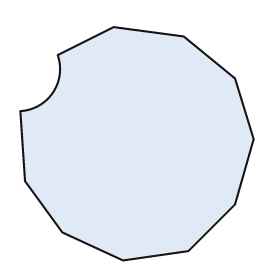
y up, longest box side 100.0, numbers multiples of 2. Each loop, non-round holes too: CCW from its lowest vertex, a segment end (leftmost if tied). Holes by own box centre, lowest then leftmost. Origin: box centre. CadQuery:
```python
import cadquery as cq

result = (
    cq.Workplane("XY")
    .moveTo(-6.0, -50.0)
    .lineTo(22.0, -46.0)
    .lineTo(42.0, -26.0)
    .lineTo(50.0, 2.0)
    .lineTo(42.0, 28.0)
    .lineTo(20.0, 46.0)
    .lineTo(-10.0, 50.0)
    .lineTo(-34.0, 38.0)
    .threePointArc((-36.0, 22.0), (-50.0, 14.0))
    .lineTo(-48.0, -16.0)
    .lineTo(-32.0, -38.0)
    .close()
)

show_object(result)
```